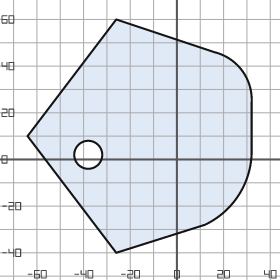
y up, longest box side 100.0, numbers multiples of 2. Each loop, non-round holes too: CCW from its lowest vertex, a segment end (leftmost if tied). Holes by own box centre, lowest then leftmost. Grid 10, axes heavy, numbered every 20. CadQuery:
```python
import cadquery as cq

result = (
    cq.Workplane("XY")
    .moveTo(-26.0, -40.0)
    .lineTo(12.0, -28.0)
    .threePointArc((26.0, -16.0), (32.0, 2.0))
    .lineTo(32.0, 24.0)
    .threePointArc((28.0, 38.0), (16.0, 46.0))
    .lineTo(-26.0, 60.0)
    .lineTo(-64.0, 10.0)
    .close()
    .moveTo(-38.0, 2.0)
    .circle(6.0)
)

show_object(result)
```